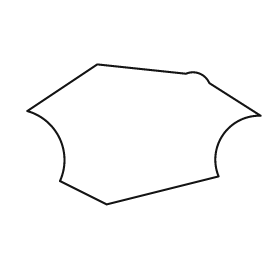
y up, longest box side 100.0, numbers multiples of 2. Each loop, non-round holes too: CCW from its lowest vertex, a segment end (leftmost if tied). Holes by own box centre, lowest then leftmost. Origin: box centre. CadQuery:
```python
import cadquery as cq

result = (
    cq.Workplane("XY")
    .moveTo(-16.0, -30.0)
    .lineTo(32.0, -18.0)
    .threePointArc((34.0, 0.0), (50.0, 8.0))
    .lineTo(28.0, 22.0)
    .threePointArc((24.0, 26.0), (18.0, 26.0))
    .lineTo(-20.0, 30.0)
    .lineTo(-50.0, 10.0)
    .threePointArc((-36.0, -2.0), (-36.0, -20.0))
    .close()
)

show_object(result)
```